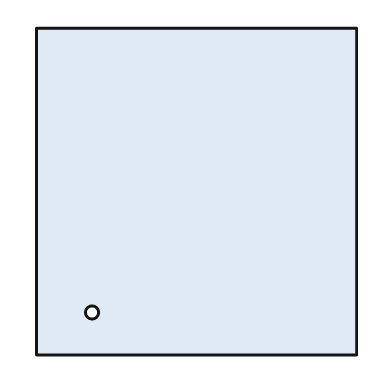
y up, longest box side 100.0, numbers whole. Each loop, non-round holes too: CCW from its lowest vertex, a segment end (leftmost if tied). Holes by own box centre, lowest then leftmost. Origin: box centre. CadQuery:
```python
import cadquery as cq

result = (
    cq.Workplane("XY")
    .moveTo(-49.0, -50.0)
    .lineTo(49.0, -50.0)
    .lineTo(49.0, 50.0)
    .lineTo(-49.0, 50.0)
    .close()
    .moveTo(-32.0, -37.0)
    .circle(2.0)
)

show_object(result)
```